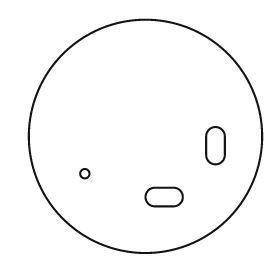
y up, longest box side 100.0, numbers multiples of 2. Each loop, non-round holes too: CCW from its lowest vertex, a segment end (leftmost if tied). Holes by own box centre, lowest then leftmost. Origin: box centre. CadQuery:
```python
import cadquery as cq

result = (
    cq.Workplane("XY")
    .moveTo(0.0, 0.0)
    .circle(50.0)
    .moveTo(4.0, -30.0)
    .lineTo(12.0, -30.0)
    .threePointArc((16.0, -26.0), (12.0, -22.0))
    .lineTo(4.0, -22.0)
    .threePointArc((0.0, -26.0), (4.0, -30.0))
    .close()
    .moveTo(-26.0, -16.0)
    .circle(2.0)
    .moveTo(26.0, -8.0)
    .threePointArc((30.0, -12.0), (34.0, -8.0))
    .lineTo(34.0, 0.0)
    .threePointArc((30.0, 4.0), (26.0, 0.0))
    .close()
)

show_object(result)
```